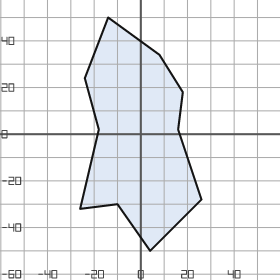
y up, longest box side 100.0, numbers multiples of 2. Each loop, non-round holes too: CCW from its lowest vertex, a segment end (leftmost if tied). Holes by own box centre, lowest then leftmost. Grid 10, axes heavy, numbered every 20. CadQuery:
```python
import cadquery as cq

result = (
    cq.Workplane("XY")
    .moveTo(4.0, -50.0)
    .lineTo(26.0, -28.0)
    .lineTo(16.0, 2.0)
    .lineTo(18.0, 18.0)
    .lineTo(8.0, 34.0)
    .lineTo(-14.0, 50.0)
    .lineTo(-24.0, 24.0)
    .lineTo(-18.0, 2.0)
    .lineTo(-26.0, -32.0)
    .lineTo(-10.0, -30.0)
    .close()
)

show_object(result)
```